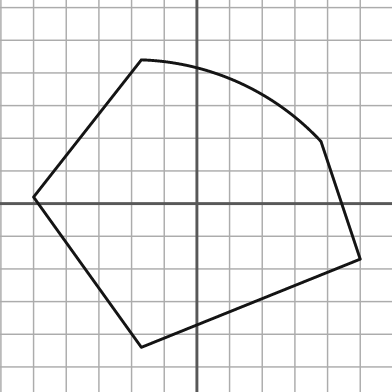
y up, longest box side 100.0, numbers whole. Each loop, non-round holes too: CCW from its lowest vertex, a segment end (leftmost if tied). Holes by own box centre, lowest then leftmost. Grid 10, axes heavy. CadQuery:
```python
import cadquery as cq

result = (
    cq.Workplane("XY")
    .moveTo(-17.0, -44.0)
    .lineTo(50.0, -17.0)
    .lineTo(38.0, 19.0)
    .threePointArc((13.0, 37.0), (-17.0, 44.0))
    .lineTo(-50.0, 2.0)
    .close()
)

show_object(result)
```